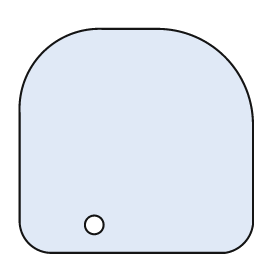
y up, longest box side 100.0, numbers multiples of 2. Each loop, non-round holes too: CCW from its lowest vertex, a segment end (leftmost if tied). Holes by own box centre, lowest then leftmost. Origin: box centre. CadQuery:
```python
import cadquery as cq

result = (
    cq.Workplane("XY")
    .moveTo(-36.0, -48.0)
    .lineTo(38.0, -48.0)
    .threePointArc((46.0, -44.0), (50.0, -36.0))
    .lineTo(50.0, 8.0)
    .threePointArc((38.0, 36.0), (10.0, 48.0))
    .lineTo(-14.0, 48.0)
    .threePointArc((-40.0, 38.0), (-50.0, 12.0))
    .lineTo(-50.0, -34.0)
    .threePointArc((-46.0, -44.0), (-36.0, -48.0))
    .close()
    .moveTo(-18.0, -36.0)
    .circle(4.0)
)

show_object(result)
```